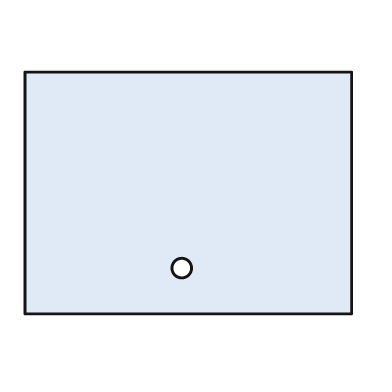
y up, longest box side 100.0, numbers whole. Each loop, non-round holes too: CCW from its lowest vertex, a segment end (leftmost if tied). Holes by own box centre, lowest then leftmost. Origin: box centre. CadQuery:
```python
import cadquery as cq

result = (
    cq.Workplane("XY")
    .moveTo(-50.0, -37.0)
    .lineTo(50.0, -37.0)
    .lineTo(50.0, 37.0)
    .lineTo(-50.0, 37.0)
    .close()
    .moveTo(-2.0, -23.0)
    .circle(3.0)
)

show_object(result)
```